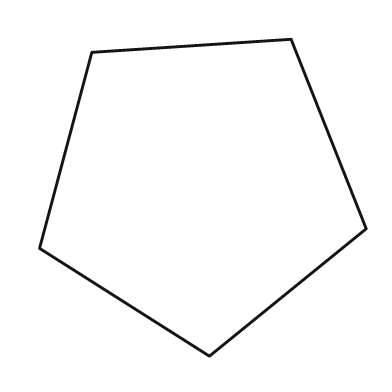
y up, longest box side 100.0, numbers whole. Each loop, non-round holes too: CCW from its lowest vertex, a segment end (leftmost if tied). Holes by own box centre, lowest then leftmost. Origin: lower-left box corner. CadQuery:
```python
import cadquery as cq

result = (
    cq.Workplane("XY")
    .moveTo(52.0, 0.0)
    .lineTo(100.0, 39.0)
    .lineTo(77.0, 97.0)
    .lineTo(16.0, 93.0)
    .lineTo(0.0, 33.0)
    .close()
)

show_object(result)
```